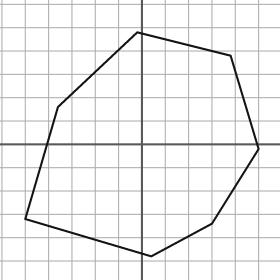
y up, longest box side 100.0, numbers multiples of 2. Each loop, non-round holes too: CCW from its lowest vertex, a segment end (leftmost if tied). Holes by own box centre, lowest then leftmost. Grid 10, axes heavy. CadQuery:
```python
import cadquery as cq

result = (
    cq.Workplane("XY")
    .moveTo(4.0, -48.0)
    .lineTo(30.0, -34.0)
    .lineTo(50.0, -2.0)
    .lineTo(38.0, 38.0)
    .lineTo(-2.0, 48.0)
    .lineTo(-36.0, 16.0)
    .lineTo(-50.0, -32.0)
    .close()
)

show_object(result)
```